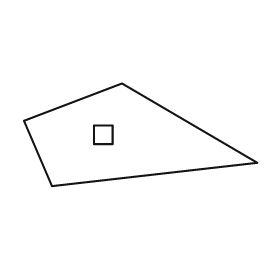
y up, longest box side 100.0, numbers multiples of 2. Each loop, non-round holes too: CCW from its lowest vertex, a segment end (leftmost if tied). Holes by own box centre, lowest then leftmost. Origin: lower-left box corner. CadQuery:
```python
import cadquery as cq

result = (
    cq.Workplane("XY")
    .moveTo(12.0, 0.0)
    .lineTo(100.0, 10.0)
    .lineTo(42.0, 44.0)
    .lineTo(0.0, 28.0)
    .close()
    .moveTo(30.0, 18.0)
    .lineTo(38.0, 18.0)
    .lineTo(38.0, 26.0)
    .lineTo(30.0, 26.0)
    .close()
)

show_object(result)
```